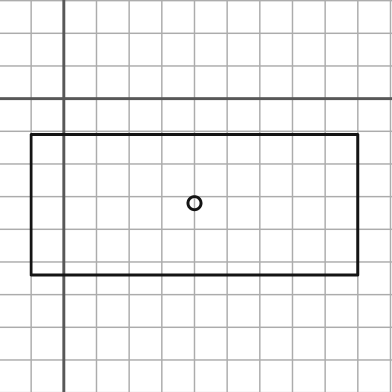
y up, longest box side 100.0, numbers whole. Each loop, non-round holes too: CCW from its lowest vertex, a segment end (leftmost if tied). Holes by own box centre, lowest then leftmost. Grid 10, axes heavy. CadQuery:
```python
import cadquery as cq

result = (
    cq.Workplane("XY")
    .moveTo(-10.0, -54.0)
    .lineTo(90.0, -54.0)
    .lineTo(90.0, -11.0)
    .lineTo(-10.0, -11.0)
    .close()
    .moveTo(40.0, -32.0)
    .circle(2.0)
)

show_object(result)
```